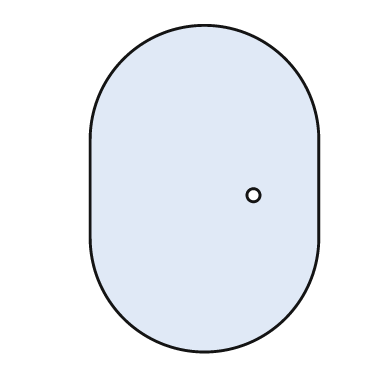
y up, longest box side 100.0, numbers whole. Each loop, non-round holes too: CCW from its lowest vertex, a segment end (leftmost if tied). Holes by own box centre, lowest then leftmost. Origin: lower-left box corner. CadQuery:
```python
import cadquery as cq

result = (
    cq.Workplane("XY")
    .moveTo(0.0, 35.0)
    .threePointArc((35.0, 0.0), (70.0, 35.0))
    .lineTo(70.0, 65.0)
    .threePointArc((35.0, 100.0), (0.0, 65.0))
    .close()
    .moveTo(50.0, 48.0)
    .circle(2.0)
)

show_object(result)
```